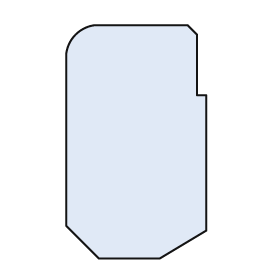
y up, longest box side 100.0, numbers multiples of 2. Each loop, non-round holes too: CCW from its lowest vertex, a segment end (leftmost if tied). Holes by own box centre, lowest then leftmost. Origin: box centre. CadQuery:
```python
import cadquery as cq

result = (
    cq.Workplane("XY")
    .moveTo(-16.0, -50.0)
    .lineTo(10.0, -50.0)
    .lineTo(30.0, -38.0)
    .lineTo(30.0, 20.0)
    .lineTo(26.0, 20.0)
    .lineTo(26.0, 46.0)
    .lineTo(22.0, 50.0)
    .lineTo(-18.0, 50.0)
    .threePointArc((-26.0, 46.0), (-30.0, 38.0))
    .lineTo(-30.0, -36.0)
    .close()
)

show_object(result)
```